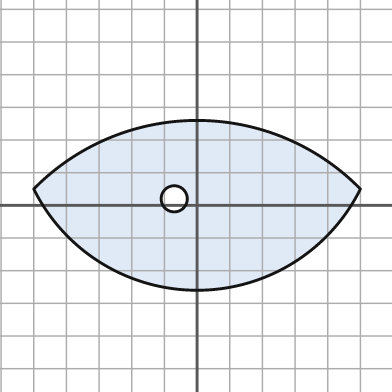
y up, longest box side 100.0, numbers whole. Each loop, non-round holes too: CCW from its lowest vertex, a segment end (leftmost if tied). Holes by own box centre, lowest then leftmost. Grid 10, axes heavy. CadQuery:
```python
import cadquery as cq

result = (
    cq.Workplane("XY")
    .moveTo(-50.0, 5.0)
    .threePointArc((0.0, -26.0), (50.0, 5.0))
    .threePointArc((0.0, 26.0), (-50.0, 5.0))
    .close()
    .moveTo(-7.0, 2.0)
    .circle(4.0)
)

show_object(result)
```